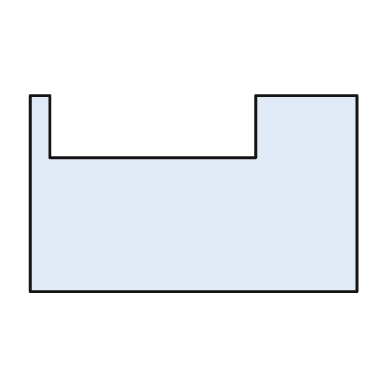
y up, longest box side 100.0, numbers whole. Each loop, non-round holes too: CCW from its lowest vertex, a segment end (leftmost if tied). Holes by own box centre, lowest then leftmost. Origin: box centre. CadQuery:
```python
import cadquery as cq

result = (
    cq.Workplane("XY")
    .moveTo(-50.0, -30.0)
    .lineTo(50.0, -30.0)
    .lineTo(50.0, 30.0)
    .lineTo(19.0, 30.0)
    .lineTo(19.0, 11.0)
    .lineTo(-44.0, 11.0)
    .lineTo(-44.0, 30.0)
    .lineTo(-50.0, 30.0)
    .close()
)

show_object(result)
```